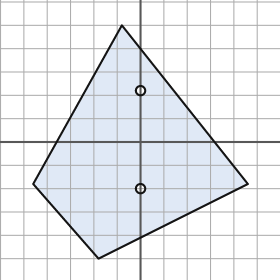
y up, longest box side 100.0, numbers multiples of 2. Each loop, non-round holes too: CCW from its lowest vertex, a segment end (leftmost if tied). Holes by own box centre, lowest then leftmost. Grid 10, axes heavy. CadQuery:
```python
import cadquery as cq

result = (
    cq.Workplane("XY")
    .moveTo(-18.0, -50.0)
    .lineTo(46.0, -18.0)
    .lineTo(-8.0, 50.0)
    .lineTo(-46.0, -18.0)
    .close()
    .moveTo(0.0, -20.0)
    .circle(2.0)
    .moveTo(0.0, 22.0)
    .circle(2.0)
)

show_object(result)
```